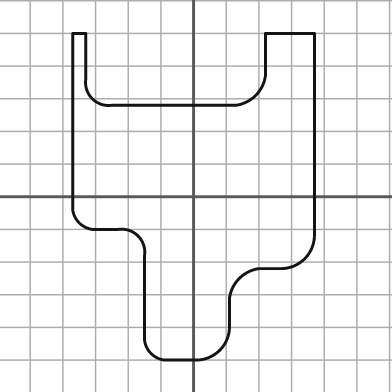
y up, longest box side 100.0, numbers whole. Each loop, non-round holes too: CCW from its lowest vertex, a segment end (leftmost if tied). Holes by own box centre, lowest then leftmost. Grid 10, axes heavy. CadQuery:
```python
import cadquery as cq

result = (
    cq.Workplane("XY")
    .moveTo(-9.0, -50.0)
    .lineTo(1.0, -50.0)
    .threePointArc((8.0, -47.0), (11.0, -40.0))
    .lineTo(11.0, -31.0)
    .threePointArc((14.0, -25.0), (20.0, -22.0))
    .lineTo(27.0, -22.0)
    .threePointArc((34.0, -19.0), (37.0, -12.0))
    .lineTo(37.0, 50.0)
    .lineTo(22.0, 50.0)
    .lineTo(22.0, 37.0)
    .threePointArc((19.0, 31.0), (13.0, 28.0))
    .lineTo(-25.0, 28.0)
    .threePointArc((-31.0, 30.0), (-33.0, 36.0))
    .lineTo(-33.0, 50.0)
    .lineTo(-37.0, 50.0)
    .lineTo(-37.0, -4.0)
    .threePointArc((-35.0, -8.0), (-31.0, -10.0))
    .lineTo(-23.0, -10.0)
    .threePointArc((-17.0, -12.0), (-15.0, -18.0))
    .lineTo(-15.0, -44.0)
    .threePointArc((-13.0, -48.0), (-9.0, -50.0))
    .close()
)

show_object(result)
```